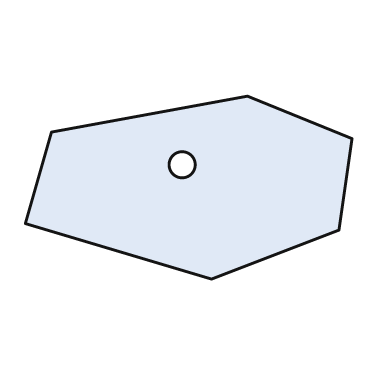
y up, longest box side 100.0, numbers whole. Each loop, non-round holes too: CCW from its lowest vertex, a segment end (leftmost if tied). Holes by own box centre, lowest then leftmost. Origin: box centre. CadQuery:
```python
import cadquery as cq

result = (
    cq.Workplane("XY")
    .moveTo(7.0, -28.0)
    .lineTo(46.0, -13.0)
    .lineTo(50.0, 15.0)
    .lineTo(18.0, 28.0)
    .lineTo(-42.0, 17.0)
    .lineTo(-50.0, -11.0)
    .close()
    .moveTo(-2.0, 7.0)
    .circle(4.0)
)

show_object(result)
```